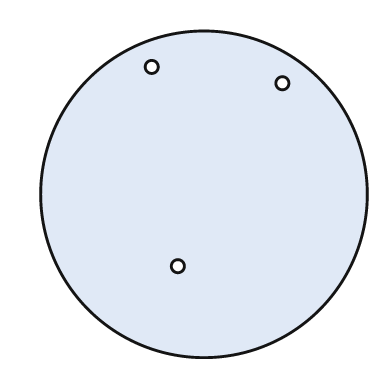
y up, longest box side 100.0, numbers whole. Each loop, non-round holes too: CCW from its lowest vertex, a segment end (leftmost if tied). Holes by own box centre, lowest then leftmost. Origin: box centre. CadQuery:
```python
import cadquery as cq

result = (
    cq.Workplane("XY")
    .moveTo(0.0, 0.0)
    .circle(50.0)
    .moveTo(-8.0, -22.0)
    .circle(2.0)
    .moveTo(24.0, 34.0)
    .circle(2.0)
    .moveTo(-16.0, 39.0)
    .circle(2.0)
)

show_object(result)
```